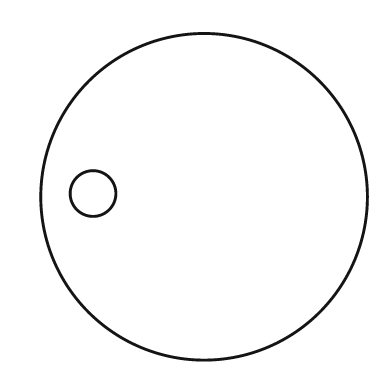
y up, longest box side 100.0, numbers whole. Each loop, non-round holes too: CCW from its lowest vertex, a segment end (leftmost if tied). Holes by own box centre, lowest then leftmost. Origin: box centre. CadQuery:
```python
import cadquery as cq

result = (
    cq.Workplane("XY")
    .moveTo(0.0, 0.0)
    .circle(50.0)
    .moveTo(-34.0, 1.0)
    .circle(7.0)
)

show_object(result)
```